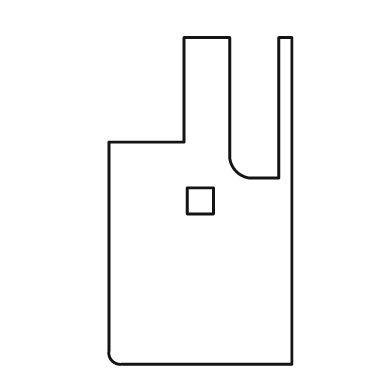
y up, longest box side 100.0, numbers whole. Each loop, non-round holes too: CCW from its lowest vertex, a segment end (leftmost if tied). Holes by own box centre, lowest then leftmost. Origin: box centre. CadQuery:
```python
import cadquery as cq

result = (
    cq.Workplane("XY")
    .moveTo(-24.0, -50.0)
    .lineTo(28.0, -50.0)
    .lineTo(28.0, 50.0)
    .lineTo(24.0, 50.0)
    .lineTo(24.0, 7.0)
    .lineTo(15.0, 7.0)
    .threePointArc((11.0, 9.0), (9.0, 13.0))
    .lineTo(9.0, 50.0)
    .lineTo(-5.0, 50.0)
    .lineTo(-5.0, 18.0)
    .lineTo(-28.0, 18.0)
    .lineTo(-28.0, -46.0)
    .threePointArc((-27.0, -49.0), (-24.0, -50.0))
    .close()
    .moveTo(-4.0, -4.0)
    .lineTo(4.0, -4.0)
    .lineTo(4.0, 4.0)
    .lineTo(-4.0, 4.0)
    .close()
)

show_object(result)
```